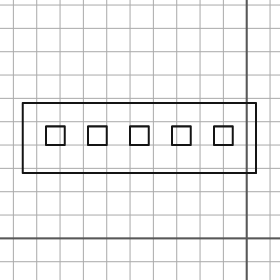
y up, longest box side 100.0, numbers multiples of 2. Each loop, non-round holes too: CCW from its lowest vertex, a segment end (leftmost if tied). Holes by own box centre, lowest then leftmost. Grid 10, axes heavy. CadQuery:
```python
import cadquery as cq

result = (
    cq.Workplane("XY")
    .moveTo(-96.0, 28.0)
    .lineTo(4.0, 28.0)
    .lineTo(4.0, 58.0)
    .lineTo(-96.0, 58.0)
    .close()
    .moveTo(-86.0, 40.0)
    .lineTo(-78.0, 40.0)
    .lineTo(-78.0, 48.0)
    .lineTo(-86.0, 48.0)
    .close()
    .moveTo(-68.0, 40.0)
    .lineTo(-60.0, 40.0)
    .lineTo(-60.0, 48.0)
    .lineTo(-68.0, 48.0)
    .close()
    .moveTo(-50.0, 40.0)
    .lineTo(-42.0, 40.0)
    .lineTo(-42.0, 48.0)
    .lineTo(-50.0, 48.0)
    .close()
    .moveTo(-32.0, 40.0)
    .lineTo(-24.0, 40.0)
    .lineTo(-24.0, 48.0)
    .lineTo(-32.0, 48.0)
    .close()
    .moveTo(-14.0, 40.0)
    .lineTo(-6.0, 40.0)
    .lineTo(-6.0, 48.0)
    .lineTo(-14.0, 48.0)
    .close()
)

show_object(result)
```